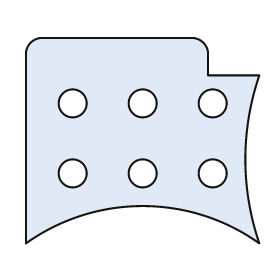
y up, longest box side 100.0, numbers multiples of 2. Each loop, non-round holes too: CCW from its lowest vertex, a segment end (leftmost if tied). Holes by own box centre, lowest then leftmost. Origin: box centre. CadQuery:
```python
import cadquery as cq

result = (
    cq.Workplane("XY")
    .moveTo(-50.0, -44.0)
    .threePointArc((0.0, -28.0), (50.0, -44.0))
    .threePointArc((44.0, -8.0), (50.0, 28.0))
    .lineTo(28.0, 28.0)
    .lineTo(28.0, 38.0)
    .threePointArc((26.0, 42.0), (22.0, 44.0))
    .lineTo(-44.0, 44.0)
    .threePointArc((-48.0, 42.0), (-50.0, 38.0))
    .close()
    .moveTo(-30.0, -14.0)
    .circle(6.0)
    .moveTo(0.0, -14.0)
    .circle(6.0)
    .moveTo(30.0, -14.0)
    .circle(6.0)
    .moveTo(-30.0, 16.0)
    .circle(6.0)
    .moveTo(0.0, 16.0)
    .circle(6.0)
    .moveTo(30.0, 16.0)
    .circle(6.0)
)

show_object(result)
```